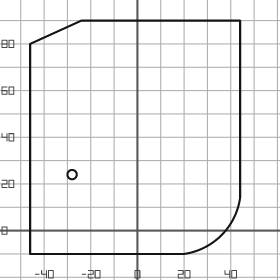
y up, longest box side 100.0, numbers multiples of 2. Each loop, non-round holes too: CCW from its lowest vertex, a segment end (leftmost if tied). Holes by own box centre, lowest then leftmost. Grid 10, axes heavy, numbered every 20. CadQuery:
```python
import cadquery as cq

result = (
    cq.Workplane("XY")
    .moveTo(-46.0, -10.0)
    .lineTo(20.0, -10.0)
    .threePointArc((36.0, -2.0), (44.0, 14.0))
    .lineTo(44.0, 90.0)
    .lineTo(-24.0, 90.0)
    .lineTo(-46.0, 80.0)
    .close()
    .moveTo(-28.0, 24.0)
    .circle(2.0)
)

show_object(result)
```